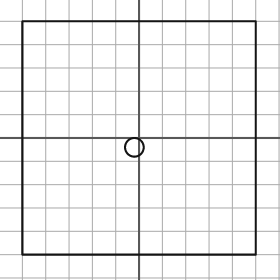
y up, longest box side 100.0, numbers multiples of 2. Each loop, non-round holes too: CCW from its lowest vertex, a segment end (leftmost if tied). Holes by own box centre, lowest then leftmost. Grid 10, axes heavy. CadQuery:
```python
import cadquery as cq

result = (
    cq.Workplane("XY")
    .moveTo(-50.0, -50.0)
    .lineTo(50.0, -50.0)
    .lineTo(50.0, 50.0)
    .lineTo(-50.0, 50.0)
    .close()
    .moveTo(-2.0, -4.0)
    .circle(4.0)
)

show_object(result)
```